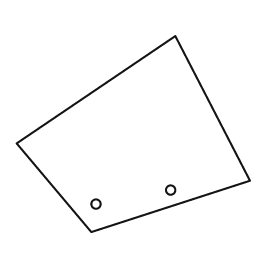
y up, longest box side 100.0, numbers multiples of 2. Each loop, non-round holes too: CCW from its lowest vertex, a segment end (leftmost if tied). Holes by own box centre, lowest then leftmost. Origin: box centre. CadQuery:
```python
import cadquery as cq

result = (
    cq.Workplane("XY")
    .moveTo(-18.0, -42.0)
    .lineTo(50.0, -20.0)
    .lineTo(18.0, 42.0)
    .lineTo(-50.0, -4.0)
    .close()
    .moveTo(-16.0, -30.0)
    .circle(2.0)
    .moveTo(16.0, -24.0)
    .circle(2.0)
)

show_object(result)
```